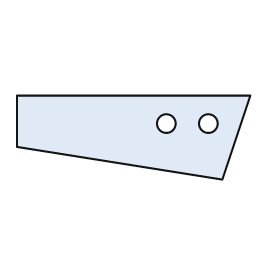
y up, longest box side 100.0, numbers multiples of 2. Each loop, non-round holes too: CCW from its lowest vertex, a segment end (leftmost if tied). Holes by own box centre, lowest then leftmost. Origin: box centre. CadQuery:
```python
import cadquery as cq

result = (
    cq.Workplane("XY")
    .moveTo(38.0, -18.0)
    .lineTo(50.0, 18.0)
    .lineTo(-50.0, 18.0)
    .lineTo(-50.0, -4.0)
    .close()
    .moveTo(14.0, 6.0)
    .circle(4.0)
    .moveTo(32.0, 6.0)
    .circle(4.0)
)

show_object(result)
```